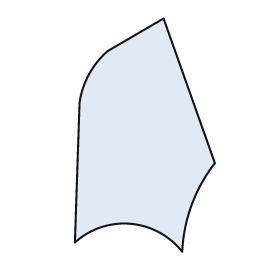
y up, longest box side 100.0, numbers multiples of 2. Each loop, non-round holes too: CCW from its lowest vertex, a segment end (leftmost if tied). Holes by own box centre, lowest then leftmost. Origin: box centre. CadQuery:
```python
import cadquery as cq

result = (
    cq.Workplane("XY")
    .moveTo(16.0, -50.0)
    .threePointArc((20.0, -30.0), (30.0, -12.0))
    .lineTo(8.0, 50.0)
    .lineTo(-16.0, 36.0)
    .threePointArc((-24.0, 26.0), (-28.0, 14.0))
    .lineTo(-30.0, -46.0)
    .threePointArc((-6.0, -38.0), (16.0, -50.0))
    .close()
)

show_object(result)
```